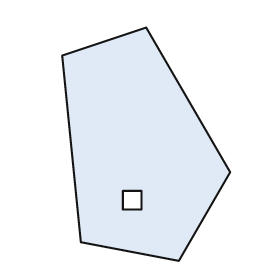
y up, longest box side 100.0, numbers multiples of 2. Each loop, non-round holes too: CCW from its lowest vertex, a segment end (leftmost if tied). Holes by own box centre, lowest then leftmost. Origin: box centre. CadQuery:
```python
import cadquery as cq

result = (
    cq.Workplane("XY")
    .moveTo(14.0, -50.0)
    .lineTo(36.0, -12.0)
    .lineTo(0.0, 50.0)
    .lineTo(-36.0, 38.0)
    .lineTo(-28.0, -42.0)
    .close()
    .moveTo(-10.0, -28.0)
    .lineTo(-2.0, -28.0)
    .lineTo(-2.0, -20.0)
    .lineTo(-10.0, -20.0)
    .close()
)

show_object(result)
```